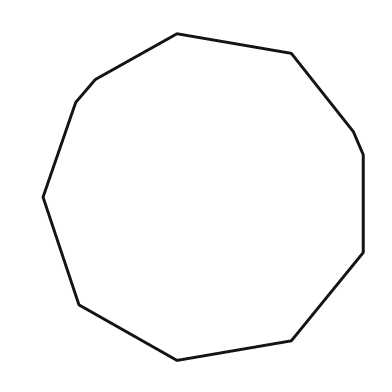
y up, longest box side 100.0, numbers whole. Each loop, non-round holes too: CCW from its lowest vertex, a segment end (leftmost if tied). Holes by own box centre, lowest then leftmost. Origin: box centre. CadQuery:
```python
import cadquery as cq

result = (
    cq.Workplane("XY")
    .moveTo(-8.0, -50.0)
    .lineTo(27.0, -44.0)
    .lineTo(49.0, -17.0)
    .lineTo(49.0, 13.0)
    .lineTo(46.0, 20.0)
    .lineTo(27.0, 44.0)
    .lineTo(-8.0, 50.0)
    .lineTo(-33.0, 36.0)
    .lineTo(-39.0, 29.0)
    .lineTo(-49.0, 0.0)
    .lineTo(-38.0, -33.0)
    .close()
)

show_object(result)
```